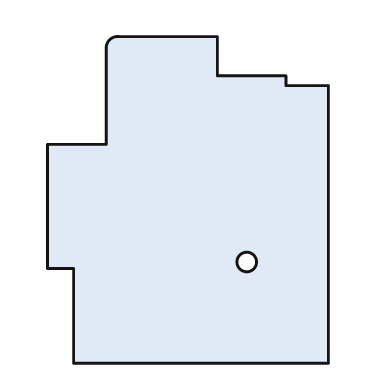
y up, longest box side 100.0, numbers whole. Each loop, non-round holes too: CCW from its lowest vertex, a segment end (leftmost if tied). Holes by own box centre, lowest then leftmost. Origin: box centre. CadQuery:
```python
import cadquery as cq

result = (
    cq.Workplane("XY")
    .moveTo(-35.0, -50.0)
    .lineTo(43.0, -50.0)
    .lineTo(43.0, 35.0)
    .lineTo(30.0, 35.0)
    .lineTo(30.0, 38.0)
    .lineTo(9.0, 38.0)
    .lineTo(9.0, 50.0)
    .lineTo(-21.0, 50.0)
    .threePointArc((-24.0, 49.0), (-25.0, 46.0))
    .lineTo(-25.0, 17.0)
    .lineTo(-43.0, 17.0)
    .lineTo(-43.0, -21.0)
    .lineTo(-35.0, -21.0)
    .close()
    .moveTo(18.0, -19.0)
    .circle(3.0)
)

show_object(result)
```